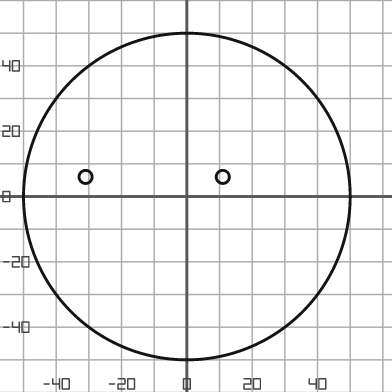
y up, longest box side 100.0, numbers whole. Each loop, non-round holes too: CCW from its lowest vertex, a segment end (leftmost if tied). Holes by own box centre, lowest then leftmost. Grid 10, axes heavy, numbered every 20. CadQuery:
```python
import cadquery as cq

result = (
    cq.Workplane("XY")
    .moveTo(0.0, 0.0)
    .circle(50.0)
    .moveTo(-31.0, 6.0)
    .circle(2.0)
    .moveTo(11.0, 6.0)
    .circle(2.0)
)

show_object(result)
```